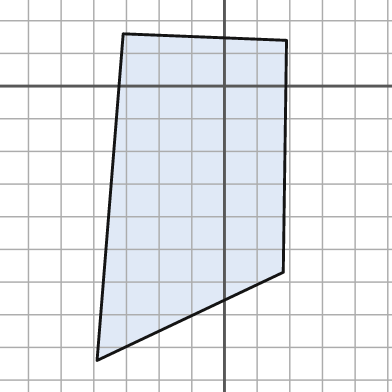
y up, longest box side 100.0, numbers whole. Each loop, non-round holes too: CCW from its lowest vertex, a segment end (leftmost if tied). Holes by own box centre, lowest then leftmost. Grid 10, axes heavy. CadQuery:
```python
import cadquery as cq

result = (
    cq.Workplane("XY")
    .moveTo(-39.0, -84.0)
    .lineTo(18.0, -57.0)
    .lineTo(19.0, 14.0)
    .lineTo(-31.0, 16.0)
    .close()
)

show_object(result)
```